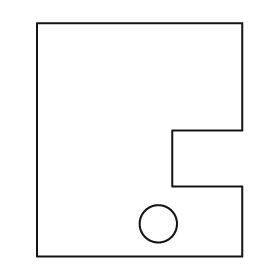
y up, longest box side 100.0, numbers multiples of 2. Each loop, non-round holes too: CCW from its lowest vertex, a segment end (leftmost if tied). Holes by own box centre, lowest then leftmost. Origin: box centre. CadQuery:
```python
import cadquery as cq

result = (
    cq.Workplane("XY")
    .moveTo(-44.0, -50.0)
    .lineTo(44.0, -50.0)
    .lineTo(44.0, -20.0)
    .lineTo(14.0, -20.0)
    .lineTo(14.0, 4.0)
    .lineTo(44.0, 4.0)
    .lineTo(44.0, 50.0)
    .lineTo(-44.0, 50.0)
    .close()
    .moveTo(8.0, -36.0)
    .circle(8.0)
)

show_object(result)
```